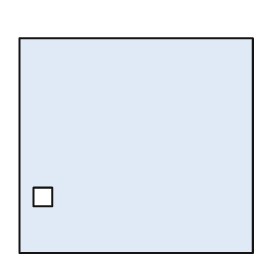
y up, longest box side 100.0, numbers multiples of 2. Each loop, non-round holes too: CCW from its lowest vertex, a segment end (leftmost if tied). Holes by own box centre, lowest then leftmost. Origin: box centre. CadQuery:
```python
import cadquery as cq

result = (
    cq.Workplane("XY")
    .moveTo(-50.0, -46.0)
    .lineTo(50.0, -46.0)
    .lineTo(50.0, 46.0)
    .lineTo(-50.0, 46.0)
    .close()
    .moveTo(-44.0, -26.0)
    .lineTo(-36.0, -26.0)
    .lineTo(-36.0, -18.0)
    .lineTo(-44.0, -18.0)
    .close()
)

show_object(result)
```